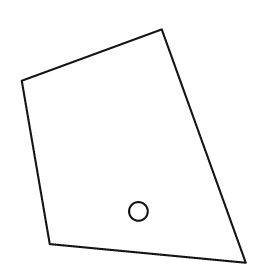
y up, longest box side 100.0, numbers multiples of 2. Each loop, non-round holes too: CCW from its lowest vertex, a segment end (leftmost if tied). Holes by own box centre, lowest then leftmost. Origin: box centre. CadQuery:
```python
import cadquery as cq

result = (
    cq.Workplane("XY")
    .moveTo(48.0, -50.0)
    .lineTo(12.0, 50.0)
    .lineTo(-48.0, 28.0)
    .lineTo(-36.0, -42.0)
    .close()
    .moveTo(2.0, -28.0)
    .circle(4.0)
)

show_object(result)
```